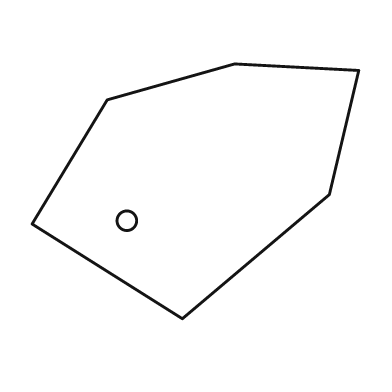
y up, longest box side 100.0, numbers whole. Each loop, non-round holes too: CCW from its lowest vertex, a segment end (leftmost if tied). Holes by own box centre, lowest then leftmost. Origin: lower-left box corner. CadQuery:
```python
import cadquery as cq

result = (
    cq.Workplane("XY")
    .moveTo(46.0, 0.0)
    .lineTo(91.0, 38.0)
    .lineTo(100.0, 76.0)
    .lineTo(62.0, 78.0)
    .lineTo(23.0, 67.0)
    .lineTo(0.0, 29.0)
    .close()
    .moveTo(29.0, 30.0)
    .circle(3.0)
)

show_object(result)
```